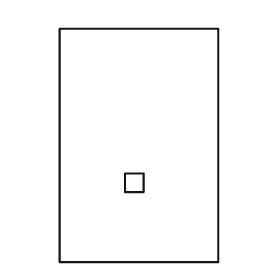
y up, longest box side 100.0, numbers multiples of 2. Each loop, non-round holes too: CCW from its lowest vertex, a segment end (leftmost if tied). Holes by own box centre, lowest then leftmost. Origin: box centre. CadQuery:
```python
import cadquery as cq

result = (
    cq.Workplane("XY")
    .moveTo(-34.0, -50.0)
    .lineTo(34.0, -50.0)
    .lineTo(34.0, 50.0)
    .lineTo(-34.0, 50.0)
    .close()
    .moveTo(-6.0, -20.0)
    .lineTo(2.0, -20.0)
    .lineTo(2.0, -12.0)
    .lineTo(-6.0, -12.0)
    .close()
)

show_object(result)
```